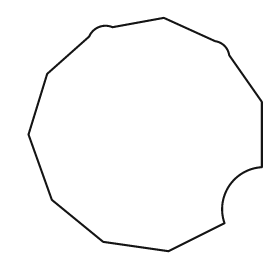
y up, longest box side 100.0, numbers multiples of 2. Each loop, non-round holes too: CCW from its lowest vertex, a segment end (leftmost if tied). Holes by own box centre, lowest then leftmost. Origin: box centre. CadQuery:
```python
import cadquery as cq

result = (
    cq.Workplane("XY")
    .moveTo(10.0, -50.0)
    .lineTo(34.0, -38.0)
    .threePointArc((36.0, -22.0), (50.0, -14.0))
    .lineTo(50.0, 14.0)
    .lineTo(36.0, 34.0)
    .threePointArc((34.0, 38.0), (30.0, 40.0))
    .lineTo(8.0, 50.0)
    .lineTo(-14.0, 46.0)
    .threePointArc((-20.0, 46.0), (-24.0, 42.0))
    .lineTo(-42.0, 26.0)
    .lineTo(-50.0, 0.0)
    .lineTo(-40.0, -28.0)
    .lineTo(-18.0, -46.0)
    .close()
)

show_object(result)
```